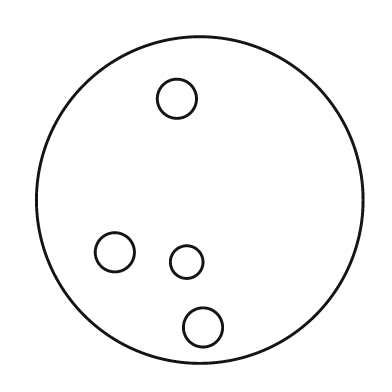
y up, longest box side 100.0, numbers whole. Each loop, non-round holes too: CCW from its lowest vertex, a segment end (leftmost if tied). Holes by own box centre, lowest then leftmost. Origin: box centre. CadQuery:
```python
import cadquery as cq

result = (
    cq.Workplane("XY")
    .moveTo(0.0, 0.0)
    .circle(50.0)
    .moveTo(1.0, -39.0)
    .circle(6.0)
    .moveTo(-4.0, -19.0)
    .circle(5.0)
    .moveTo(-26.0, -16.0)
    .circle(6.0)
    .moveTo(-7.0, 31.0)
    .circle(6.0)
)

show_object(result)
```